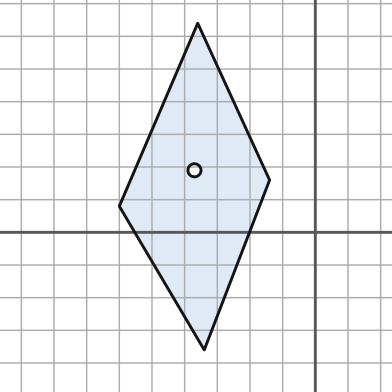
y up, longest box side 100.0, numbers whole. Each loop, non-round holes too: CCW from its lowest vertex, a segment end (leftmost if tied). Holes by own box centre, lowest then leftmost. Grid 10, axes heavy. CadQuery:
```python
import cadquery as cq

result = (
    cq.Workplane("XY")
    .moveTo(-34.0, -36.0)
    .lineTo(-14.0, 16.0)
    .lineTo(-36.0, 64.0)
    .lineTo(-60.0, 8.0)
    .close()
    .moveTo(-37.0, 19.0)
    .circle(2.0)
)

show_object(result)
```